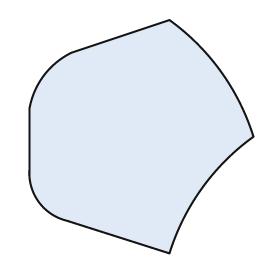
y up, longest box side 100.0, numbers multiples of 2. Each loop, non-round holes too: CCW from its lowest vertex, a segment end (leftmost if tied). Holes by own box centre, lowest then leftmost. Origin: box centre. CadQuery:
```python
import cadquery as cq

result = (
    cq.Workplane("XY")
    .moveTo(12.0, -50.0)
    .threePointArc((26.0, -22.0), (48.0, 0.0))
    .threePointArc((34.0, 28.0), (12.0, 50.0))
    .lineTo(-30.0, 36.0)
    .threePointArc((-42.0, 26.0), (-48.0, 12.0))
    .lineTo(-48.0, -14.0)
    .threePointArc((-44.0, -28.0), (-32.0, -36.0))
    .close()
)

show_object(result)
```